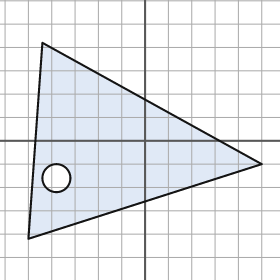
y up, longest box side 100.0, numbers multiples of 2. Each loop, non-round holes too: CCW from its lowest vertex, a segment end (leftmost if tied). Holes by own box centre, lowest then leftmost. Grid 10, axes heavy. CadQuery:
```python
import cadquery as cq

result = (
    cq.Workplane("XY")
    .moveTo(-50.0, -42.0)
    .lineTo(50.0, -10.0)
    .lineTo(-44.0, 42.0)
    .close()
    .moveTo(-38.0, -16.0)
    .circle(6.0)
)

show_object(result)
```